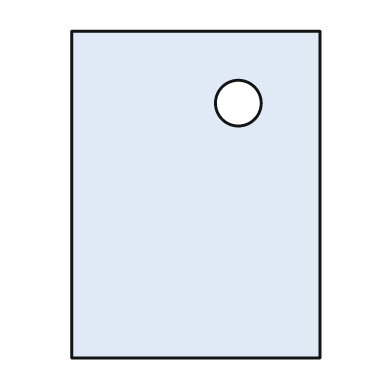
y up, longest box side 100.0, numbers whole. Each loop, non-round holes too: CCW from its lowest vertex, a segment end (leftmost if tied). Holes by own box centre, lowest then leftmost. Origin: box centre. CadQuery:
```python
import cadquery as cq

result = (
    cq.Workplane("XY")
    .moveTo(-38.0, -50.0)
    .lineTo(38.0, -50.0)
    .lineTo(38.0, 50.0)
    .lineTo(-38.0, 50.0)
    .close()
    .moveTo(13.0, 28.0)
    .circle(7.0)
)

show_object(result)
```